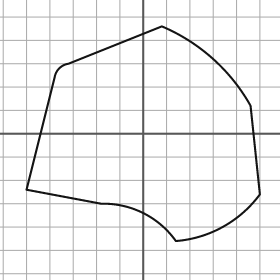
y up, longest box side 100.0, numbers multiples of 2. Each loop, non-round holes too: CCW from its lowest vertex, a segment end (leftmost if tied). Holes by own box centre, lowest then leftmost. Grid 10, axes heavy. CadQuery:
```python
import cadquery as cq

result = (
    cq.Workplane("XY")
    .moveTo(14.0, -46.0)
    .threePointArc((34.0, -40.0), (50.0, -26.0))
    .lineTo(46.0, 12.0)
    .threePointArc((30.0, 32.0), (8.0, 46.0))
    .lineTo(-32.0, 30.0)
    .threePointArc((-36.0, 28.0), (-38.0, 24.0))
    .lineTo(-50.0, -24.0)
    .lineTo(-18.0, -30.0)
    .threePointArc((0.0, -34.0), (14.0, -46.0))
    .close()
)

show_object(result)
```